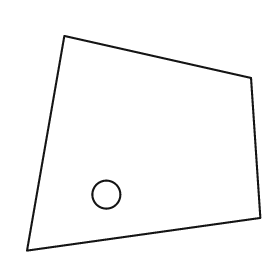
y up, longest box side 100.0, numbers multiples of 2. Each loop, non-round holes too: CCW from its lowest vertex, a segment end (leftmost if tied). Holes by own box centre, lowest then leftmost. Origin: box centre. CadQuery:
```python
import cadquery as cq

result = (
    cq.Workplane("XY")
    .moveTo(-50.0, -46.0)
    .lineTo(50.0, -32.0)
    .lineTo(46.0, 28.0)
    .lineTo(-34.0, 46.0)
    .close()
    .moveTo(-16.0, -22.0)
    .circle(6.0)
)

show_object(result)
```